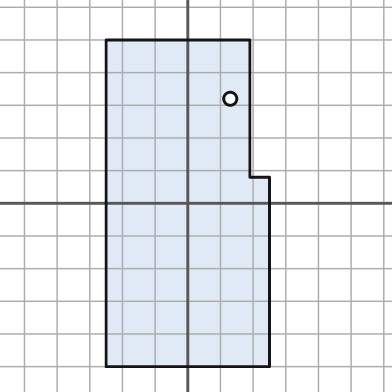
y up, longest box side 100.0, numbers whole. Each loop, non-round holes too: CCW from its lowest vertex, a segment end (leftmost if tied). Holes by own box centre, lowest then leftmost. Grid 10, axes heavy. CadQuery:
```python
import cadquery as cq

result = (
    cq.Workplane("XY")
    .moveTo(-25.0, -50.0)
    .lineTo(25.0, -50.0)
    .lineTo(25.0, 8.0)
    .lineTo(19.0, 8.0)
    .lineTo(19.0, 50.0)
    .lineTo(-25.0, 50.0)
    .close()
    .moveTo(13.0, 32.0)
    .circle(2.0)
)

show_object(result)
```